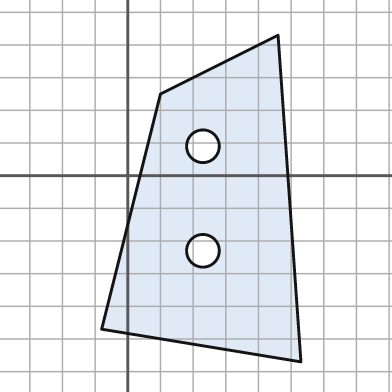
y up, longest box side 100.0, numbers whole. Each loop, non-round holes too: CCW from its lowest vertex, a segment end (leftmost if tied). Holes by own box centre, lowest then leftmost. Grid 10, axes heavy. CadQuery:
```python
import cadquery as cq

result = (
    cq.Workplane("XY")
    .moveTo(53.0, -57.0)
    .lineTo(46.0, 43.0)
    .lineTo(10.0, 25.0)
    .lineTo(-8.0, -47.0)
    .close()
    .moveTo(23.0, -23.0)
    .circle(5.0)
    .moveTo(23.0, 9.0)
    .circle(5.0)
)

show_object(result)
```